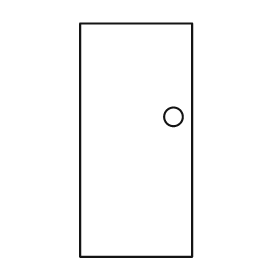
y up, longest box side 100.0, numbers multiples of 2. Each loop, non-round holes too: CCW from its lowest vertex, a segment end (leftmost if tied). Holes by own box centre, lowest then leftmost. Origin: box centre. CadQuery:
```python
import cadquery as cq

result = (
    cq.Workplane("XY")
    .moveTo(-24.0, -50.0)
    .lineTo(24.0, -50.0)
    .lineTo(24.0, 50.0)
    .lineTo(-24.0, 50.0)
    .close()
    .moveTo(16.0, 10.0)
    .circle(4.0)
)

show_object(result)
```